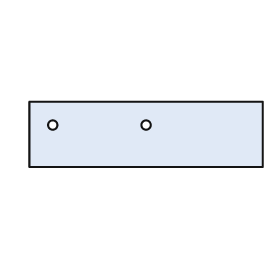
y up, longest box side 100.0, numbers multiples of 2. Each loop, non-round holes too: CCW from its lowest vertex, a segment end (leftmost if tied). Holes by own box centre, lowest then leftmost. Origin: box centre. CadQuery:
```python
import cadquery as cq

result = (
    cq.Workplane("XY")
    .moveTo(-50.0, -14.0)
    .lineTo(50.0, -14.0)
    .lineTo(50.0, 14.0)
    .lineTo(-50.0, 14.0)
    .close()
    .moveTo(-40.0, 4.0)
    .circle(2.0)
    .moveTo(0.0, 4.0)
    .circle(2.0)
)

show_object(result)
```